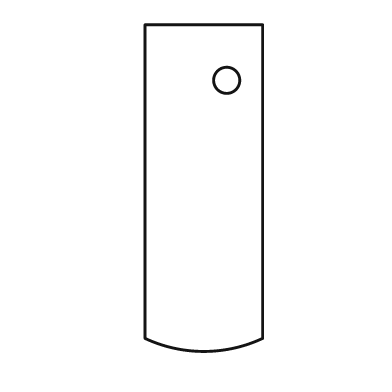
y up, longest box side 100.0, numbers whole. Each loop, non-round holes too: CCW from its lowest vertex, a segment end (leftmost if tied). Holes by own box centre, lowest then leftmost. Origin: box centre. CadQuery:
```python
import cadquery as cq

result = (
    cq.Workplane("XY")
    .moveTo(-18.0, -46.0)
    .threePointArc((0.0, -50.0), (18.0, -46.0))
    .lineTo(18.0, 50.0)
    .lineTo(-18.0, 50.0)
    .close()
    .moveTo(7.0, 33.0)
    .circle(4.0)
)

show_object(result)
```